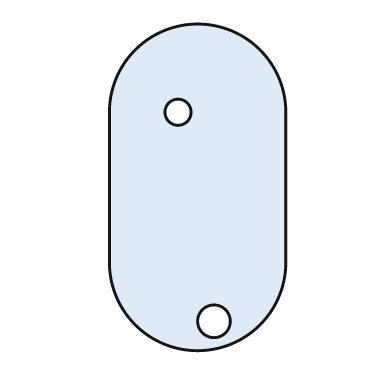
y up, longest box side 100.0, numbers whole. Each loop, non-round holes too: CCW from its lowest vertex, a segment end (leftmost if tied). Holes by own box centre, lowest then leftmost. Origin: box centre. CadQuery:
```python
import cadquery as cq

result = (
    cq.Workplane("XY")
    .moveTo(-27.0, -23.0)
    .threePointArc((0.0, -50.0), (27.0, -23.0))
    .lineTo(27.0, 23.0)
    .threePointArc((0.0, 50.0), (-27.0, 23.0))
    .close()
    .moveTo(5.0, -41.0)
    .circle(5.0)
    .moveTo(-6.0, 23.0)
    .circle(4.0)
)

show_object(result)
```